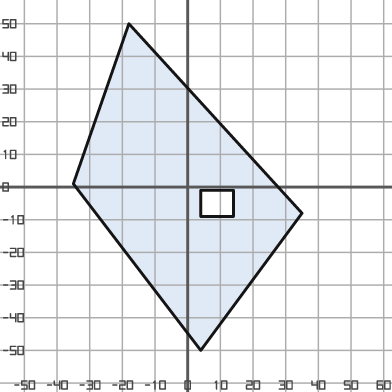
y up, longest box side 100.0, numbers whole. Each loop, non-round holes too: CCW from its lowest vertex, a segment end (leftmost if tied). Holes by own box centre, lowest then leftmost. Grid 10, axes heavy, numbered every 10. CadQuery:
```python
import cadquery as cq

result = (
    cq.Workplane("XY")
    .moveTo(4.0, -50.0)
    .lineTo(35.0, -8.0)
    .lineTo(-18.0, 50.0)
    .lineTo(-35.0, 1.0)
    .close()
    .moveTo(4.0, -9.0)
    .lineTo(14.0, -9.0)
    .lineTo(14.0, -1.0)
    .lineTo(4.0, -1.0)
    .close()
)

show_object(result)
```